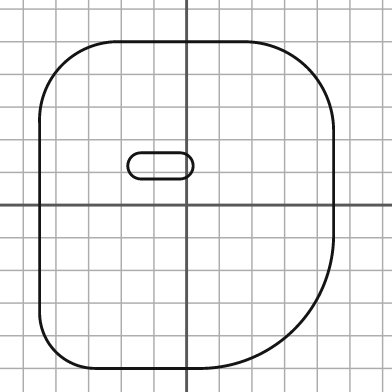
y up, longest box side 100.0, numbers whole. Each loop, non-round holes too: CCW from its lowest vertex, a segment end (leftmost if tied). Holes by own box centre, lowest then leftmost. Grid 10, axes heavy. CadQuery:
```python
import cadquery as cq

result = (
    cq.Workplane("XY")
    .moveTo(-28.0, -50.0)
    .lineTo(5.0, -50.0)
    .threePointArc((33.0, -38.0), (45.0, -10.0))
    .lineTo(45.0, 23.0)
    .threePointArc((37.0, 42.0), (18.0, 50.0))
    .lineTo(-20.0, 50.0)
    .threePointArc((-38.0, 43.0), (-45.0, 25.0))
    .lineTo(-45.0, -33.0)
    .threePointArc((-40.0, -45.0), (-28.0, -50.0))
    .close()
    .moveTo(-14.0, 8.0)
    .lineTo(-2.0, 8.0)
    .threePointArc((2.0, 12.0), (-2.0, 16.0))
    .lineTo(-14.0, 16.0)
    .threePointArc((-18.0, 12.0), (-14.0, 8.0))
    .close()
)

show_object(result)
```